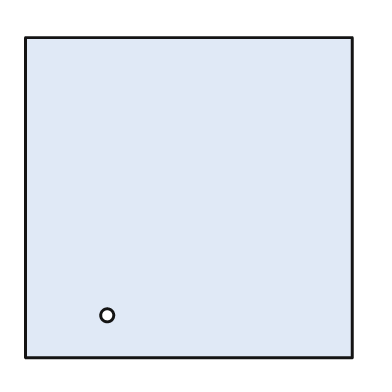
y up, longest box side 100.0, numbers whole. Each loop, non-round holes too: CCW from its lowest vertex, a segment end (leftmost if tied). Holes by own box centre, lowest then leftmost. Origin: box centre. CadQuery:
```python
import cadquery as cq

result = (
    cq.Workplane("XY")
    .moveTo(-50.0, -49.0)
    .lineTo(50.0, -49.0)
    .lineTo(50.0, 49.0)
    .lineTo(-50.0, 49.0)
    .close()
    .moveTo(-25.0, -36.0)
    .circle(2.0)
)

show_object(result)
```